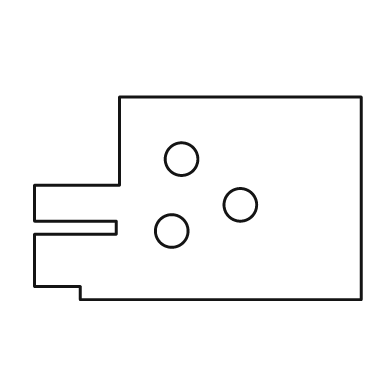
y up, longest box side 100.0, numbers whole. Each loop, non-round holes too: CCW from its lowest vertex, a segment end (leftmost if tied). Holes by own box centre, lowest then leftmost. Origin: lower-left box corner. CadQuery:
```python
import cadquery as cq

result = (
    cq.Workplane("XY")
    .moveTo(14.0, 0.0)
    .lineTo(100.0, 0.0)
    .lineTo(100.0, 62.0)
    .lineTo(26.0, 62.0)
    .lineTo(26.0, 35.0)
    .lineTo(0.0, 35.0)
    .lineTo(0.0, 24.0)
    .lineTo(25.0, 24.0)
    .lineTo(25.0, 20.0)
    .lineTo(0.0, 20.0)
    .lineTo(0.0, 4.0)
    .lineTo(14.0, 4.0)
    .close()
    .moveTo(42.0, 21.0)
    .circle(5.0)
    .moveTo(63.0, 29.0)
    .circle(5.0)
    .moveTo(45.0, 43.0)
    .circle(5.0)
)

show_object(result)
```